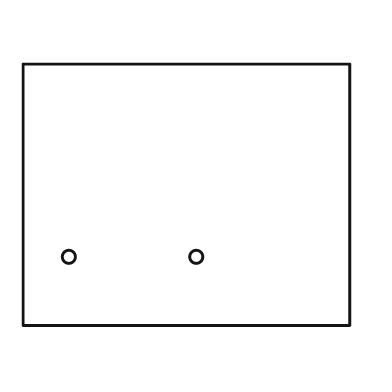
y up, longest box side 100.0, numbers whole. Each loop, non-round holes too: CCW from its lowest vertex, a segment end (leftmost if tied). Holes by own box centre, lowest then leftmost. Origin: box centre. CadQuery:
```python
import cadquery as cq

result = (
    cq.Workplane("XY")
    .moveTo(-50.0, -40.0)
    .lineTo(50.0, -40.0)
    .lineTo(50.0, 40.0)
    .lineTo(-50.0, 40.0)
    .close()
    .moveTo(-36.0, -19.0)
    .circle(2.0)
    .moveTo(3.0, -19.0)
    .circle(2.0)
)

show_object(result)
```